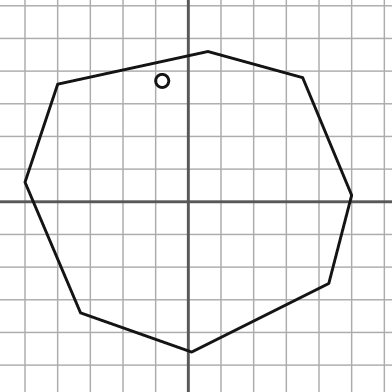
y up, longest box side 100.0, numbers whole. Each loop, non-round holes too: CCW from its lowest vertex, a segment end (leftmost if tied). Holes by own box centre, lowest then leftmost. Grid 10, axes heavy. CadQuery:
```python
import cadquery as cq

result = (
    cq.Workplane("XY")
    .moveTo(1.0, -46.0)
    .lineTo(43.0, -25.0)
    .lineTo(50.0, 2.0)
    .lineTo(35.0, 38.0)
    .lineTo(6.0, 46.0)
    .lineTo(-40.0, 36.0)
    .lineTo(-50.0, 6.0)
    .lineTo(-33.0, -34.0)
    .close()
    .moveTo(-8.0, 37.0)
    .circle(2.0)
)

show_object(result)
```